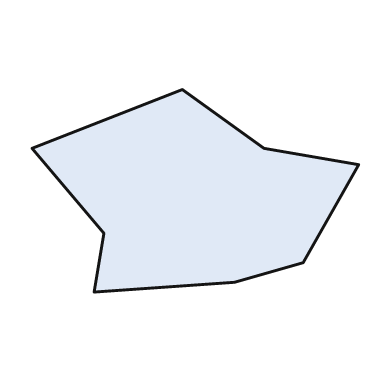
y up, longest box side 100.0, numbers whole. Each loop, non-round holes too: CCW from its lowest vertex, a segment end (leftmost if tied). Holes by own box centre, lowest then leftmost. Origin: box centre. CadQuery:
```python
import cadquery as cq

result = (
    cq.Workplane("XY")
    .moveTo(-31.0, -31.0)
    .lineTo(12.0, -28.0)
    .lineTo(33.0, -22.0)
    .lineTo(50.0, 8.0)
    .lineTo(21.0, 13.0)
    .lineTo(-4.0, 31.0)
    .lineTo(-50.0, 13.0)
    .lineTo(-28.0, -13.0)
    .close()
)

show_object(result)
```